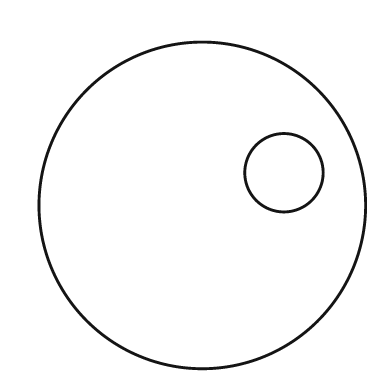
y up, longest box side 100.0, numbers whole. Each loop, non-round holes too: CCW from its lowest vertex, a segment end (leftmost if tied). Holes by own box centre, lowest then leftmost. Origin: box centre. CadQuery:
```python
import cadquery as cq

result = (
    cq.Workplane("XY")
    .moveTo(0.0, 0.0)
    .circle(50.0)
    .moveTo(25.0, 10.0)
    .circle(12.0)
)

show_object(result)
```